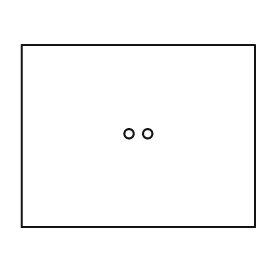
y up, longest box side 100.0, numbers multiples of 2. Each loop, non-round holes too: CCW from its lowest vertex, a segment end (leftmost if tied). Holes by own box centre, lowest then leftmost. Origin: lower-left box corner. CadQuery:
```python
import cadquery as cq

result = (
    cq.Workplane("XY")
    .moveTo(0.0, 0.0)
    .lineTo(100.0, 0.0)
    .lineTo(100.0, 78.0)
    .lineTo(0.0, 78.0)
    .close()
    .moveTo(46.0, 40.0)
    .circle(2.0)
    .moveTo(54.0, 40.0)
    .circle(2.0)
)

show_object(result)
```